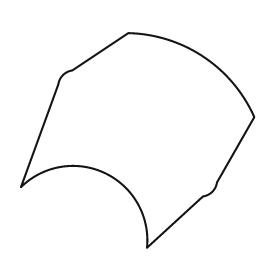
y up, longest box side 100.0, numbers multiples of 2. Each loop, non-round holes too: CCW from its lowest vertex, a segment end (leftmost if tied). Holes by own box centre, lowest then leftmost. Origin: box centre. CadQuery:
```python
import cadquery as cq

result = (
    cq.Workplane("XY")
    .moveTo(4.0, -46.0)
    .lineTo(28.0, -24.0)
    .threePointArc((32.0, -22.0), (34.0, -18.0))
    .lineTo(50.0, 10.0)
    .threePointArc((28.0, 36.0), (-4.0, 46.0))
    .lineTo(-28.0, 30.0)
    .threePointArc((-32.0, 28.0), (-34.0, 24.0))
    .lineTo(-50.0, -20.0)
    .threePointArc((-14.0, -14.0), (4.0, -46.0))
    .close()
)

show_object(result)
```